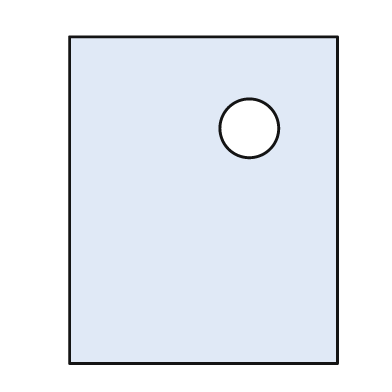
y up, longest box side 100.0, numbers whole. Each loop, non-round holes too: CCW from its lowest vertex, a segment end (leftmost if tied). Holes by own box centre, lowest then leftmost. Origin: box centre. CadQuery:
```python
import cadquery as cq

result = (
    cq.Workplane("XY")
    .moveTo(-41.0, -50.0)
    .lineTo(41.0, -50.0)
    .lineTo(41.0, 50.0)
    .lineTo(-41.0, 50.0)
    .close()
    .moveTo(14.0, 22.0)
    .circle(9.0)
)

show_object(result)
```